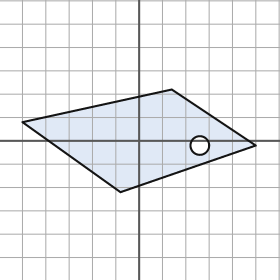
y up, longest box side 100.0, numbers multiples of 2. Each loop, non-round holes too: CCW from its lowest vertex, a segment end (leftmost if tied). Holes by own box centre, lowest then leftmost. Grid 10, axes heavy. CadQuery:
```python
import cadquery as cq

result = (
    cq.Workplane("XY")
    .moveTo(-8.0, -22.0)
    .lineTo(50.0, -2.0)
    .lineTo(14.0, 22.0)
    .lineTo(-50.0, 8.0)
    .close()
    .moveTo(26.0, -2.0)
    .circle(4.0)
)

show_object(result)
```